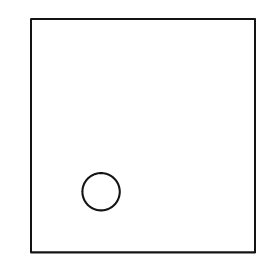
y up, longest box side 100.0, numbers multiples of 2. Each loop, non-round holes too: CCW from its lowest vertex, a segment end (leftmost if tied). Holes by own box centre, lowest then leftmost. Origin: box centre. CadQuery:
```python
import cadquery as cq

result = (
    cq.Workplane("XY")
    .moveTo(-48.0, -50.0)
    .lineTo(48.0, -50.0)
    .lineTo(48.0, 50.0)
    .lineTo(-48.0, 50.0)
    .close()
    .moveTo(-18.0, -24.0)
    .circle(8.0)
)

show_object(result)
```